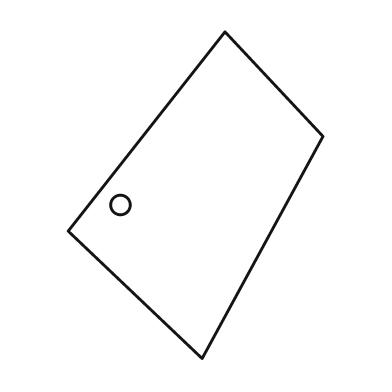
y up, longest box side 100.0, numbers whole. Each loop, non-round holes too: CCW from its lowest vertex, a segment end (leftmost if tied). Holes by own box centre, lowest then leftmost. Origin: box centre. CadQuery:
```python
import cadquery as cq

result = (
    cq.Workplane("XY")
    .moveTo(2.0, -50.0)
    .lineTo(39.0, 18.0)
    .lineTo(9.0, 50.0)
    .lineTo(-39.0, -11.0)
    .close()
    .moveTo(-23.0, -3.0)
    .circle(3.0)
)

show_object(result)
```